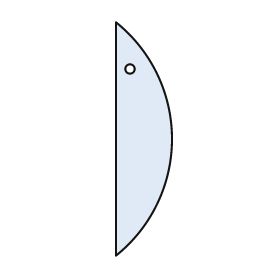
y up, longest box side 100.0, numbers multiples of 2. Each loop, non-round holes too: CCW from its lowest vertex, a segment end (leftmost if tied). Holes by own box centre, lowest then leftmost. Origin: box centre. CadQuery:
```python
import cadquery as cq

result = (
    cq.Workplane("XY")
    .moveTo(-12.0, -50.0)
    .threePointArc((12.0, 0.0), (-12.0, 50.0))
    .close()
    .moveTo(-6.0, 30.0)
    .circle(2.0)
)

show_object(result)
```